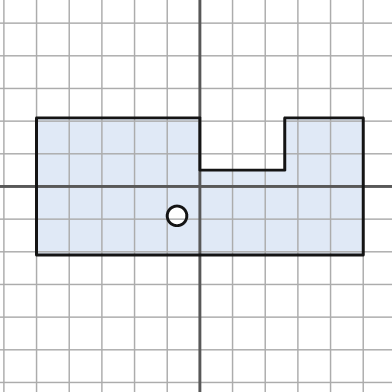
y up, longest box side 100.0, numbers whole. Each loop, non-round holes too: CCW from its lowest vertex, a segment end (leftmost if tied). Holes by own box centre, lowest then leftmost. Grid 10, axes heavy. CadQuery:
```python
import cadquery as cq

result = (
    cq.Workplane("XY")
    .moveTo(-50.0, -21.0)
    .lineTo(50.0, -21.0)
    .lineTo(50.0, 21.0)
    .lineTo(26.0, 21.0)
    .lineTo(26.0, 5.0)
    .lineTo(0.0, 5.0)
    .lineTo(0.0, 21.0)
    .lineTo(-50.0, 21.0)
    .close()
    .moveTo(-7.0, -9.0)
    .circle(3.0)
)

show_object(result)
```